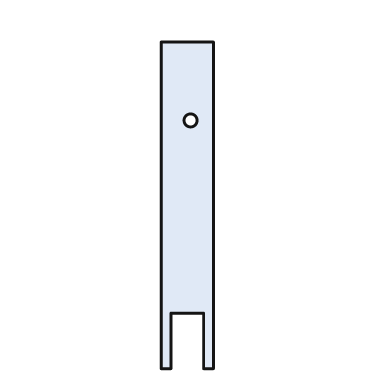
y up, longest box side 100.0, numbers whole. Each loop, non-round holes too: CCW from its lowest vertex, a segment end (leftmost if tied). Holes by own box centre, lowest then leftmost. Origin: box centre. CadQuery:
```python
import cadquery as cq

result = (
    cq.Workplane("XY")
    .moveTo(-8.0, -50.0)
    .lineTo(-5.0, -50.0)
    .lineTo(-5.0, -33.0)
    .lineTo(5.0, -33.0)
    .lineTo(5.0, -50.0)
    .lineTo(8.0, -50.0)
    .lineTo(8.0, 50.0)
    .lineTo(-8.0, 50.0)
    .close()
    .moveTo(1.0, 26.0)
    .circle(2.0)
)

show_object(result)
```